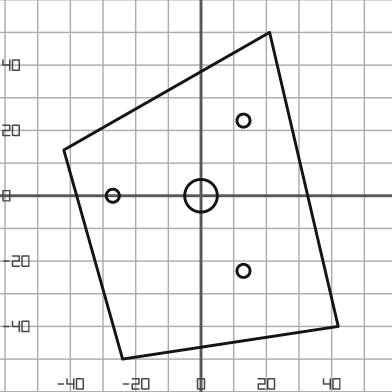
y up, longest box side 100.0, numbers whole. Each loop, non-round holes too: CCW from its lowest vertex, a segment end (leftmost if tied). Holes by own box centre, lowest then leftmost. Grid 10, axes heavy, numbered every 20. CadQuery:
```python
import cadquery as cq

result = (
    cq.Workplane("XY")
    .moveTo(-24.0, -50.0)
    .lineTo(42.0, -40.0)
    .lineTo(21.0, 50.0)
    .lineTo(-42.0, 14.0)
    .close()
    .moveTo(13.0, -23.0)
    .circle(2.0)
    .moveTo(-27.0, 0.0)
    .circle(2.0)
    .moveTo(0.0, 0.0)
    .circle(5.0)
    .moveTo(13.0, 23.0)
    .circle(2.0)
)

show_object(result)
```